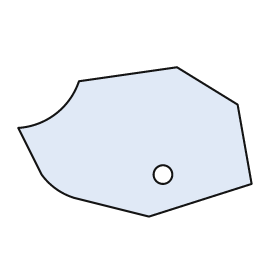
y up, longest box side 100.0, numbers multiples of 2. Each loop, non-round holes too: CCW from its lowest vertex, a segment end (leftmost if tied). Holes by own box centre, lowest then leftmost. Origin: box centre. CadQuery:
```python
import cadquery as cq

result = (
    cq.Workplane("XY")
    .moveTo(6.0, -32.0)
    .lineTo(50.0, -18.0)
    .lineTo(44.0, 16.0)
    .lineTo(18.0, 32.0)
    .lineTo(-24.0, 26.0)
    .threePointArc((-34.0, 12.0), (-50.0, 6.0))
    .lineTo(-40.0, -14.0)
    .threePointArc((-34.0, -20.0), (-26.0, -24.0))
    .close()
    .moveTo(12.0, -14.0)
    .circle(4.0)
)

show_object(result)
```